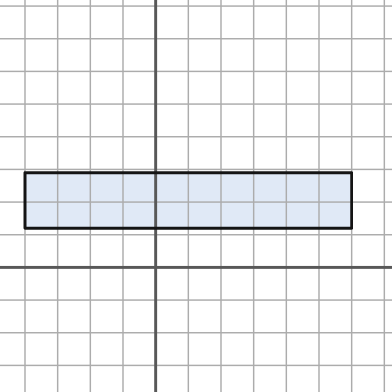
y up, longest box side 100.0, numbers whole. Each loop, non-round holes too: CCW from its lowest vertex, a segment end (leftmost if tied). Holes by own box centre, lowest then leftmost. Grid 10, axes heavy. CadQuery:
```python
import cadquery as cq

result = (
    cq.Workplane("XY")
    .moveTo(-40.0, 12.0)
    .lineTo(60.0, 12.0)
    .lineTo(60.0, 29.0)
    .lineTo(-40.0, 29.0)
    .close()
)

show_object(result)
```